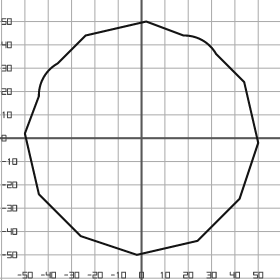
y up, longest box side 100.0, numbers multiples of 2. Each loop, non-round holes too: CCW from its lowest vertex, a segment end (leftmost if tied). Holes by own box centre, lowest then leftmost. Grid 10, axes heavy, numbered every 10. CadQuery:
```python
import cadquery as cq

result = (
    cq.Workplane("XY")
    .moveTo(-2.0, -50.0)
    .lineTo(24.0, -44.0)
    .lineTo(42.0, -26.0)
    .lineTo(50.0, -2.0)
    .lineTo(44.0, 24.0)
    .lineTo(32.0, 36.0)
    .threePointArc((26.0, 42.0), (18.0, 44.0))
    .lineTo(2.0, 50.0)
    .lineTo(-24.0, 44.0)
    .lineTo(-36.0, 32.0)
    .threePointArc((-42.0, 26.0), (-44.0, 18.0))
    .lineTo(-50.0, 2.0)
    .lineTo(-44.0, -24.0)
    .lineTo(-26.0, -42.0)
    .close()
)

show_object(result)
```